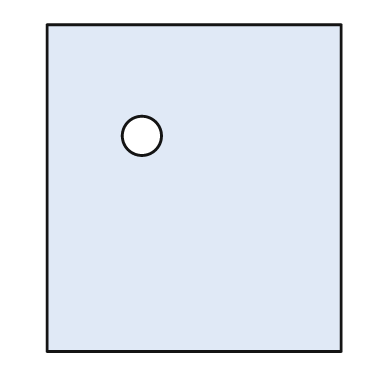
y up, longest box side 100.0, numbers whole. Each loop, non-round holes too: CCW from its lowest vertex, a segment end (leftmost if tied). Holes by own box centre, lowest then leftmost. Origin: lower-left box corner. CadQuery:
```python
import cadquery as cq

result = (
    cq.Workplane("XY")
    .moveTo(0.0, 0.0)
    .lineTo(90.0, 0.0)
    .lineTo(90.0, 100.0)
    .lineTo(0.0, 100.0)
    .close()
    .moveTo(29.0, 66.0)
    .circle(6.0)
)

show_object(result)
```